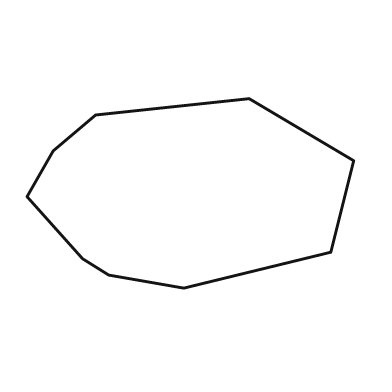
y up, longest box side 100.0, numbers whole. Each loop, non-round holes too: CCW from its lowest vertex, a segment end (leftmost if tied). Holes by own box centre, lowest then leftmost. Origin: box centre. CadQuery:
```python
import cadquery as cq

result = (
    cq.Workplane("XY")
    .moveTo(-2.0, -29.0)
    .lineTo(43.0, -18.0)
    .lineTo(50.0, 10.0)
    .lineTo(18.0, 29.0)
    .lineTo(-29.0, 24.0)
    .lineTo(-42.0, 13.0)
    .lineTo(-50.0, -1.0)
    .lineTo(-33.0, -20.0)
    .lineTo(-25.0, -25.0)
    .close()
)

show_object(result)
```